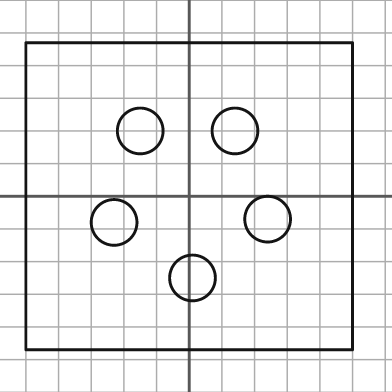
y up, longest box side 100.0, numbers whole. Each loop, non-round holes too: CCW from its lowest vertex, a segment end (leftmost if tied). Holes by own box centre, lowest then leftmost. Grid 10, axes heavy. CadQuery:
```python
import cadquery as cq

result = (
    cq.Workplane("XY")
    .moveTo(-50.0, -47.0)
    .lineTo(50.0, -47.0)
    .lineTo(50.0, 47.0)
    .lineTo(-50.0, 47.0)
    .close()
    .moveTo(1.0, -25.0)
    .circle(7.0)
    .moveTo(-23.0, -8.0)
    .circle(7.0)
    .moveTo(24.0, -7.0)
    .circle(7.0)
    .moveTo(-15.0, 20.0)
    .circle(7.0)
    .moveTo(14.0, 20.0)
    .circle(7.0)
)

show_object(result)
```